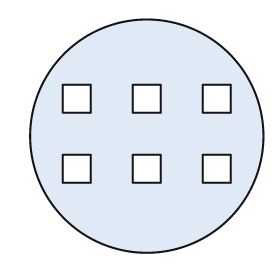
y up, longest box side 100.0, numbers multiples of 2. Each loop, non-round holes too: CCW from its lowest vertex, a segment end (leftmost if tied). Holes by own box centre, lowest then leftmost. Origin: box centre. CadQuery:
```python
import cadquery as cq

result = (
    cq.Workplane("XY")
    .moveTo(0.0, 0.0)
    .circle(50.0)
    .moveTo(-36.0, -20.0)
    .lineTo(-24.0, -20.0)
    .lineTo(-24.0, -8.0)
    .lineTo(-36.0, -8.0)
    .close()
    .moveTo(-6.0, -20.0)
    .lineTo(6.0, -20.0)
    .lineTo(6.0, -8.0)
    .lineTo(-6.0, -8.0)
    .close()
    .moveTo(24.0, -20.0)
    .lineTo(36.0, -20.0)
    .lineTo(36.0, -8.0)
    .lineTo(24.0, -8.0)
    .close()
    .moveTo(-36.0, 10.0)
    .lineTo(-24.0, 10.0)
    .lineTo(-24.0, 22.0)
    .lineTo(-36.0, 22.0)
    .close()
    .moveTo(-6.0, 10.0)
    .lineTo(6.0, 10.0)
    .lineTo(6.0, 22.0)
    .lineTo(-6.0, 22.0)
    .close()
    .moveTo(24.0, 10.0)
    .lineTo(36.0, 10.0)
    .lineTo(36.0, 22.0)
    .lineTo(24.0, 22.0)
    .close()
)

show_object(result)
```